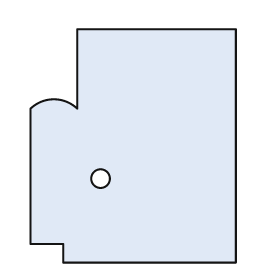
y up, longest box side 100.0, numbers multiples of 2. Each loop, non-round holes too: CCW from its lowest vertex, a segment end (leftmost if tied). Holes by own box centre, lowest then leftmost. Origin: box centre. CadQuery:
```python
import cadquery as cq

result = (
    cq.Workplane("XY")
    .moveTo(-30.0, -50.0)
    .lineTo(44.0, -50.0)
    .lineTo(44.0, 50.0)
    .lineTo(-24.0, 50.0)
    .lineTo(-24.0, 16.0)
    .threePointArc((-34.0, 20.0), (-44.0, 16.0))
    .lineTo(-44.0, -42.0)
    .lineTo(-30.0, -42.0)
    .close()
    .moveTo(-14.0, -14.0)
    .circle(4.0)
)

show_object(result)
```